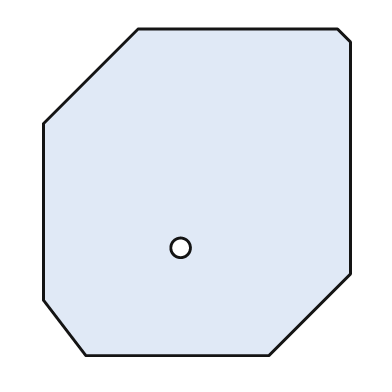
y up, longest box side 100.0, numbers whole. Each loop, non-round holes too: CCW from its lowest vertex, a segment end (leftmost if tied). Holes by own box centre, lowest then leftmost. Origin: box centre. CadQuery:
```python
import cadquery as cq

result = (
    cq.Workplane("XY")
    .moveTo(-34.0, -50.0)
    .lineTo(22.0, -50.0)
    .lineTo(47.0, -25.0)
    .lineTo(47.0, 46.0)
    .lineTo(43.0, 50.0)
    .lineTo(-18.0, 50.0)
    .lineTo(-47.0, 21.0)
    .lineTo(-47.0, -33.0)
    .close()
    .moveTo(-5.0, -17.0)
    .circle(3.0)
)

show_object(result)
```